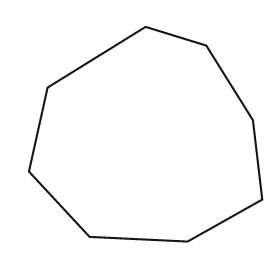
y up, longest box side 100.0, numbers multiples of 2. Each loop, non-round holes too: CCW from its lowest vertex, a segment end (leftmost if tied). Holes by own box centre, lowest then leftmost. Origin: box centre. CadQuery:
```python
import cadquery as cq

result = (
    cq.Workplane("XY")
    .moveTo(18.0, -46.0)
    .lineTo(50.0, -28.0)
    .lineTo(46.0, 6.0)
    .lineTo(26.0, 38.0)
    .lineTo(0.0, 46.0)
    .lineTo(-42.0, 20.0)
    .lineTo(-50.0, -16.0)
    .lineTo(-24.0, -44.0)
    .close()
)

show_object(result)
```